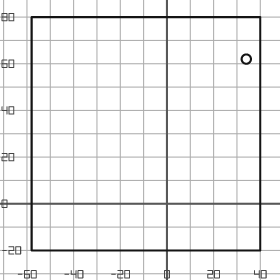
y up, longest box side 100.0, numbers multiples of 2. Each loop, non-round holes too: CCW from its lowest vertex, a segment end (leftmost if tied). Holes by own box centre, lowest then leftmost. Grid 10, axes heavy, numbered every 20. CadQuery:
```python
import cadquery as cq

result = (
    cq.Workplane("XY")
    .moveTo(-58.0, -20.0)
    .lineTo(40.0, -20.0)
    .lineTo(40.0, 80.0)
    .lineTo(-58.0, 80.0)
    .close()
    .moveTo(34.0, 62.0)
    .circle(2.0)
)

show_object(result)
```